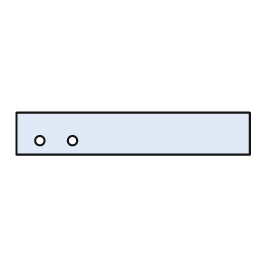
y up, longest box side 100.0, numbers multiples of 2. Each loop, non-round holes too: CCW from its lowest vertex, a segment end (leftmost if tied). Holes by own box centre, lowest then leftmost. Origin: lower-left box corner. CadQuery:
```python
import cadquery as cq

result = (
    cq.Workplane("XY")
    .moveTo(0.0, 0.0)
    .lineTo(100.0, 0.0)
    .lineTo(100.0, 18.0)
    .lineTo(0.0, 18.0)
    .close()
    .moveTo(10.0, 6.0)
    .circle(2.0)
    .moveTo(24.0, 6.0)
    .circle(2.0)
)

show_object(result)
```